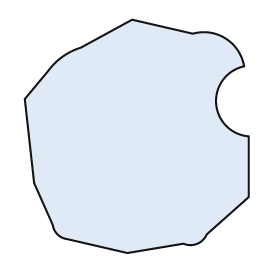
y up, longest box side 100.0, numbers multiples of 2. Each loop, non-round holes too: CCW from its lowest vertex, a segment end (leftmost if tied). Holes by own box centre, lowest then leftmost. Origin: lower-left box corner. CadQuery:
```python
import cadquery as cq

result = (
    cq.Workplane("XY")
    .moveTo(44.0, 0.0)
    .lineTo(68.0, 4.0)
    .threePointArc((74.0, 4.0), (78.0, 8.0))
    .lineTo(96.0, 24.0)
    .lineTo(96.0, 50.0)
    .threePointArc((82.0, 64.0), (94.0, 80.0))
    .threePointArc((86.0, 92.0), (72.0, 94.0))
    .lineTo(46.0, 100.0)
    .lineTo(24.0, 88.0)
    .threePointArc((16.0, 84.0), (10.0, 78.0))
    .lineTo(0.0, 66.0)
    .lineTo(4.0, 30.0)
    .lineTo(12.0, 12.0)
    .threePointArc((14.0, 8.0), (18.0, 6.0))
    .close()
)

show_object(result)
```